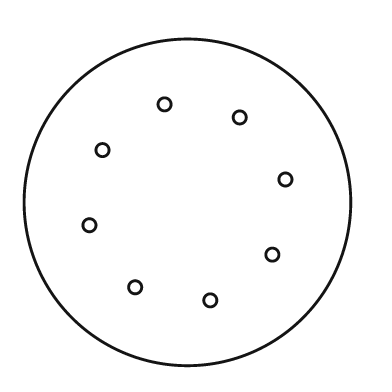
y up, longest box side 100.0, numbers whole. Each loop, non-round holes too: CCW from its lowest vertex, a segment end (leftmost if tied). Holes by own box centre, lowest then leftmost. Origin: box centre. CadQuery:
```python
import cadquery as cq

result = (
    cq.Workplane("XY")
    .moveTo(0.0, 0.0)
    .circle(50.0)
    .moveTo(7.0, -30.0)
    .circle(2.0)
    .moveTo(-16.0, -26.0)
    .circle(2.0)
    .moveTo(26.0, -16.0)
    .circle(2.0)
    .moveTo(-30.0, -7.0)
    .circle(2.0)
    .moveTo(30.0, 7.0)
    .circle(2.0)
    .moveTo(-26.0, 16.0)
    .circle(2.0)
    .moveTo(16.0, 26.0)
    .circle(2.0)
    .moveTo(-7.0, 30.0)
    .circle(2.0)
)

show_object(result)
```